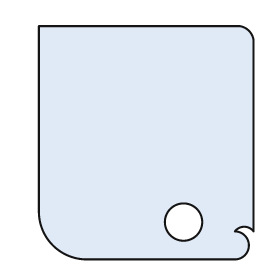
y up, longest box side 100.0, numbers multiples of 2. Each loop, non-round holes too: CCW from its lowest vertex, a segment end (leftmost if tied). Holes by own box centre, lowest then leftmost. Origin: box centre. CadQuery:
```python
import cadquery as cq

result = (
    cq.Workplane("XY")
    .moveTo(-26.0, -50.0)
    .lineTo(38.0, -50.0)
    .threePointArc((44.0, -44.0), (38.0, -38.0))
    .threePointArc((42.0, -36.0), (46.0, -38.0))
    .lineTo(46.0, 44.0)
    .threePointArc((44.0, 48.0), (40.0, 50.0))
    .lineTo(-46.0, 50.0)
    .lineTo(-46.0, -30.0)
    .threePointArc((-40.0, -44.0), (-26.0, -50.0))
    .close()
    .moveTo(16.0, -34.0)
    .circle(8.0)
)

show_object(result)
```